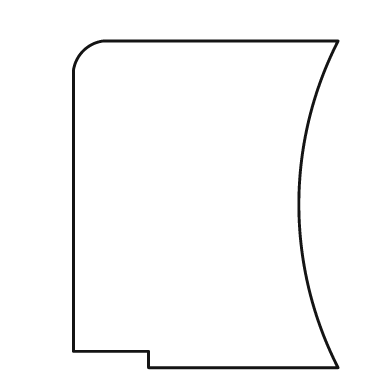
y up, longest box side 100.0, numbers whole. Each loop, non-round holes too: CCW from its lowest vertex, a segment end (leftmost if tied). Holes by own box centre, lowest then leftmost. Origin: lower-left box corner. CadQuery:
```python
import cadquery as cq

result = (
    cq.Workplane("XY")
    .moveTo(23.0, 0.0)
    .lineTo(81.0, 0.0)
    .threePointArc((69.0, 50.0), (81.0, 100.0))
    .lineTo(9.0, 100.0)
    .threePointArc((3.0, 97.0), (0.0, 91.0))
    .lineTo(0.0, 5.0)
    .lineTo(23.0, 5.0)
    .close()
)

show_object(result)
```